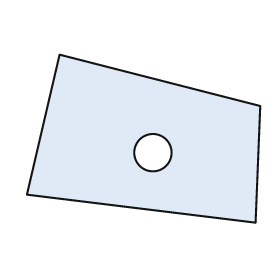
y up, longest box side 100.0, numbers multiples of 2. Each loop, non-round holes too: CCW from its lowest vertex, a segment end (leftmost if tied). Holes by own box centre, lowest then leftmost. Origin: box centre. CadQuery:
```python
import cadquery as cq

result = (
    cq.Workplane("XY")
    .moveTo(48.0, -36.0)
    .lineTo(50.0, 14.0)
    .lineTo(-36.0, 36.0)
    .lineTo(-50.0, -24.0)
    .close()
    .moveTo(4.0, -6.0)
    .circle(8.0)
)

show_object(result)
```